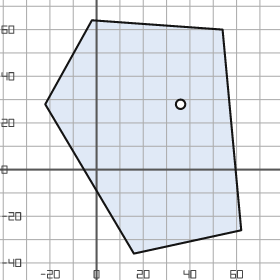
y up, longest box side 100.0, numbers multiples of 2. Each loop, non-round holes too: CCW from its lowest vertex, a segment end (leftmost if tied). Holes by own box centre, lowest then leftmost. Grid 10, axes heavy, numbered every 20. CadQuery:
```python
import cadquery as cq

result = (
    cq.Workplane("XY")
    .moveTo(16.0, -36.0)
    .lineTo(62.0, -26.0)
    .lineTo(54.0, 60.0)
    .lineTo(-2.0, 64.0)
    .lineTo(-22.0, 28.0)
    .close()
    .moveTo(36.0, 28.0)
    .circle(2.0)
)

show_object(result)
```